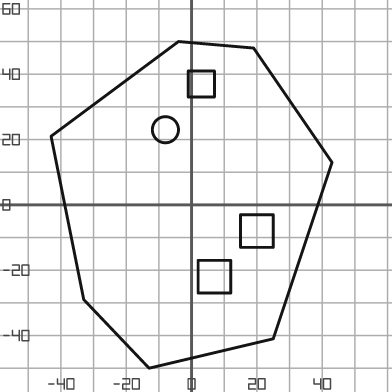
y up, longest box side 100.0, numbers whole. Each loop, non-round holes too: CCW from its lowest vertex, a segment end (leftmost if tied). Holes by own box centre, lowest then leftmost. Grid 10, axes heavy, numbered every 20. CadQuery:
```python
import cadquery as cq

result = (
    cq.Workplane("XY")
    .moveTo(-13.0, -50.0)
    .lineTo(25.0, -41.0)
    .lineTo(43.0, 13.0)
    .lineTo(19.0, 48.0)
    .lineTo(-4.0, 50.0)
    .lineTo(-43.0, 21.0)
    .lineTo(-33.0, -29.0)
    .close()
    .moveTo(2.0, -27.0)
    .lineTo(12.0, -27.0)
    .lineTo(12.0, -17.0)
    .lineTo(2.0, -17.0)
    .close()
    .moveTo(15.0, -13.0)
    .lineTo(25.0, -13.0)
    .lineTo(25.0, -3.0)
    .lineTo(15.0, -3.0)
    .close()
    .moveTo(-8.0, 23.0)
    .circle(4.0)
    .moveTo(-1.0, 33.0)
    .lineTo(7.0, 33.0)
    .lineTo(7.0, 41.0)
    .lineTo(-1.0, 41.0)
    .close()
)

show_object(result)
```